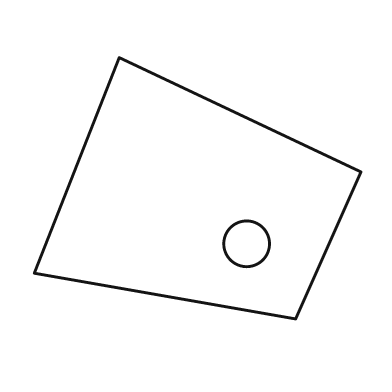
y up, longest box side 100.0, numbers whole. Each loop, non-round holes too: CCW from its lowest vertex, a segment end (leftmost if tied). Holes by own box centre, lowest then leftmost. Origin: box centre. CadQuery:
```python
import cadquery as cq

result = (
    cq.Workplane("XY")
    .moveTo(30.0, -40.0)
    .lineTo(50.0, 5.0)
    .lineTo(-24.0, 40.0)
    .lineTo(-50.0, -26.0)
    .close()
    .moveTo(15.0, -17.0)
    .circle(7.0)
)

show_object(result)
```